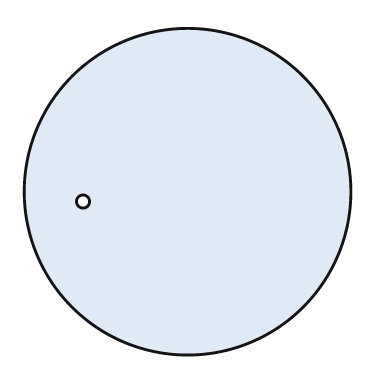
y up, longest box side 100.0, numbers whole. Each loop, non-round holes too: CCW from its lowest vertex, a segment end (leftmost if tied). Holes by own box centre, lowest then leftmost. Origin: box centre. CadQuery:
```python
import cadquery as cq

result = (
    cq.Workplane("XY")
    .moveTo(0.0, 0.0)
    .circle(50.0)
    .moveTo(-32.0, -3.0)
    .circle(2.0)
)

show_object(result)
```